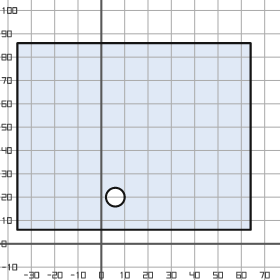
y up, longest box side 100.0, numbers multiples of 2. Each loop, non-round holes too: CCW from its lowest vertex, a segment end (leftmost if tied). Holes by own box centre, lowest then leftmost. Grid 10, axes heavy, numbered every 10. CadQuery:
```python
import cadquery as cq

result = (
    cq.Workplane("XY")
    .moveTo(-36.0, 6.0)
    .lineTo(64.0, 6.0)
    .lineTo(64.0, 86.0)
    .lineTo(-36.0, 86.0)
    .close()
    .moveTo(6.0, 20.0)
    .circle(4.0)
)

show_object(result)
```